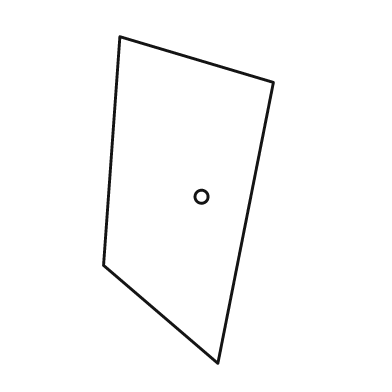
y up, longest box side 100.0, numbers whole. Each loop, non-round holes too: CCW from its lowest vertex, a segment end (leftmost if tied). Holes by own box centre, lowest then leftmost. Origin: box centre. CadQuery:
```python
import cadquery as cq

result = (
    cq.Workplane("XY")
    .moveTo(9.0, -50.0)
    .lineTo(26.0, 36.0)
    .lineTo(-21.0, 50.0)
    .lineTo(-26.0, -20.0)
    .close()
    .moveTo(4.0, 1.0)
    .circle(2.0)
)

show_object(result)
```